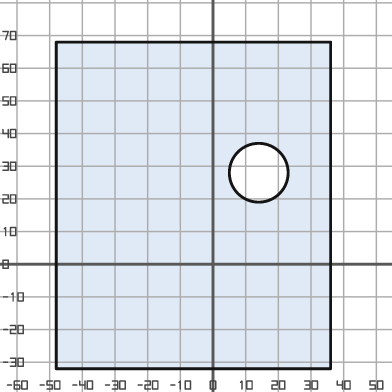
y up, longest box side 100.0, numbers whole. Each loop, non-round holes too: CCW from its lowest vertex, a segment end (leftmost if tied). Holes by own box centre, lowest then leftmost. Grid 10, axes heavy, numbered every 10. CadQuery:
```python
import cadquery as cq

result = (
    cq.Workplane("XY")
    .moveTo(-48.0, -32.0)
    .lineTo(36.0, -32.0)
    .lineTo(36.0, 68.0)
    .lineTo(-48.0, 68.0)
    .close()
    .moveTo(14.0, 28.0)
    .circle(9.0)
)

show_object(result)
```